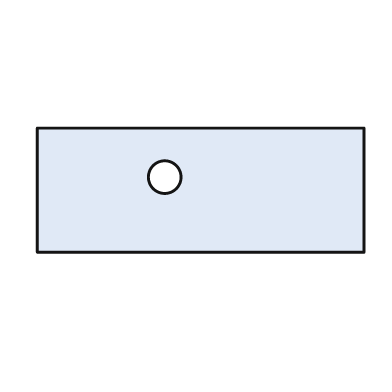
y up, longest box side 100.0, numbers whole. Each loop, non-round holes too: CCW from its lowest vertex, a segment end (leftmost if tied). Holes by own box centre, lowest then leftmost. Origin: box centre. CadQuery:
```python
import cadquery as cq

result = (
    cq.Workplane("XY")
    .moveTo(-50.0, -19.0)
    .lineTo(50.0, -19.0)
    .lineTo(50.0, 19.0)
    .lineTo(-50.0, 19.0)
    .close()
    .moveTo(-11.0, 4.0)
    .circle(5.0)
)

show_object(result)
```